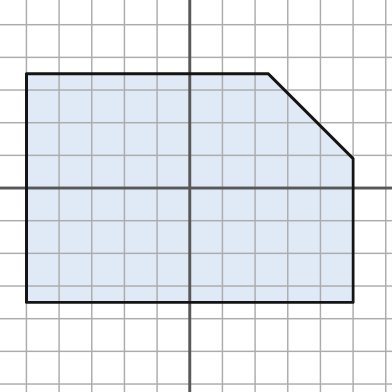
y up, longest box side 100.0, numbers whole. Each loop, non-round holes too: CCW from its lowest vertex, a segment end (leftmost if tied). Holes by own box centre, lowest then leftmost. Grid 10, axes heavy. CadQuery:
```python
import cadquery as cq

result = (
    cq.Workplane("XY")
    .moveTo(-50.0, -35.0)
    .lineTo(50.0, -35.0)
    .lineTo(50.0, 9.0)
    .lineTo(24.0, 35.0)
    .lineTo(-50.0, 35.0)
    .close()
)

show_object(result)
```